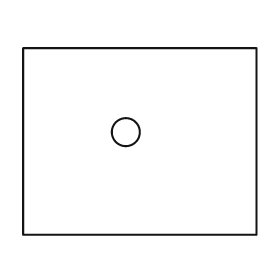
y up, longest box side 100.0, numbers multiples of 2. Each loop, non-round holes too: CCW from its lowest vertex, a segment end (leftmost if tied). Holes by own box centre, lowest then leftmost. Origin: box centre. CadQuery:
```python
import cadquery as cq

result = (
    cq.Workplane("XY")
    .moveTo(-50.0, -40.0)
    .lineTo(50.0, -40.0)
    .lineTo(50.0, 40.0)
    .lineTo(-50.0, 40.0)
    .close()
    .moveTo(-6.0, 4.0)
    .circle(6.0)
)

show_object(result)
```